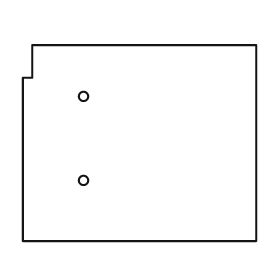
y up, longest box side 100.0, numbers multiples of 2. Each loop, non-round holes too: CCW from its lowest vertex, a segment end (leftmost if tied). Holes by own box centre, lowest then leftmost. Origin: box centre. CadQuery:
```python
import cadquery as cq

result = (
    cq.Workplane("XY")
    .moveTo(-50.0, -42.0)
    .lineTo(50.0, -42.0)
    .lineTo(50.0, 42.0)
    .lineTo(-46.0, 42.0)
    .lineTo(-46.0, 28.0)
    .lineTo(-50.0, 28.0)
    .close()
    .moveTo(-24.0, -16.0)
    .circle(2.0)
    .moveTo(-24.0, 20.0)
    .circle(2.0)
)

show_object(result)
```